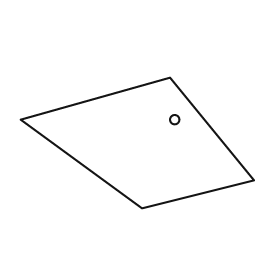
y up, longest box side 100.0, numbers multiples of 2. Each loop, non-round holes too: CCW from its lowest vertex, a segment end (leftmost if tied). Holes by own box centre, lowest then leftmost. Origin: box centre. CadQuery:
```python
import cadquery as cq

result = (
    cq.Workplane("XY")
    .moveTo(2.0, -28.0)
    .lineTo(50.0, -16.0)
    .lineTo(14.0, 28.0)
    .lineTo(-50.0, 10.0)
    .close()
    .moveTo(16.0, 10.0)
    .circle(2.0)
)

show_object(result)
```